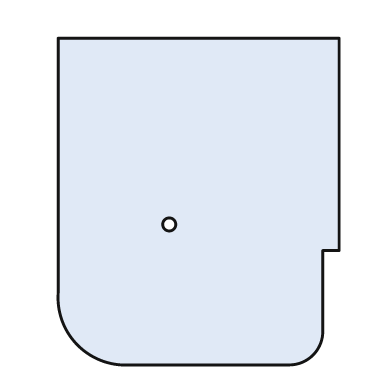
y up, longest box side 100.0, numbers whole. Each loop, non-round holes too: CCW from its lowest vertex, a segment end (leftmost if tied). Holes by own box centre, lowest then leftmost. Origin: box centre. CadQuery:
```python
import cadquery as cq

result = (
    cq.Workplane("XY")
    .moveTo(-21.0, -50.0)
    .lineTo(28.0, -50.0)
    .threePointArc((35.0, -47.0), (38.0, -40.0))
    .lineTo(38.0, -15.0)
    .lineTo(43.0, -15.0)
    .lineTo(43.0, 50.0)
    .lineTo(-43.0, 50.0)
    .lineTo(-43.0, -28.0)
    .threePointArc((-37.0, -44.0), (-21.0, -50.0))
    .close()
    .moveTo(-9.0, -7.0)
    .circle(2.0)
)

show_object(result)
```